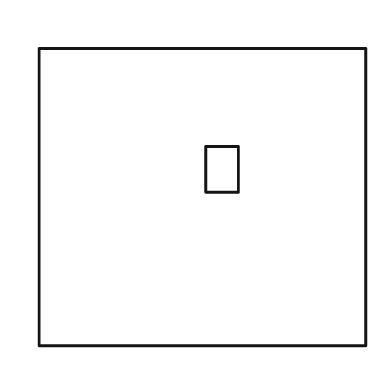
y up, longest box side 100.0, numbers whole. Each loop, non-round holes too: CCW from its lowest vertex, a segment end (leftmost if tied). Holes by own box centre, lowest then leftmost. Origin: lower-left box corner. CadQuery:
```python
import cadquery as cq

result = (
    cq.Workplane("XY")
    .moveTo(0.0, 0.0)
    .lineTo(100.0, 0.0)
    .lineTo(100.0, 91.0)
    .lineTo(0.0, 91.0)
    .close()
    .moveTo(51.0, 47.0)
    .lineTo(61.0, 47.0)
    .lineTo(61.0, 61.0)
    .lineTo(51.0, 61.0)
    .close()
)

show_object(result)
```